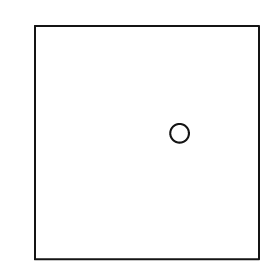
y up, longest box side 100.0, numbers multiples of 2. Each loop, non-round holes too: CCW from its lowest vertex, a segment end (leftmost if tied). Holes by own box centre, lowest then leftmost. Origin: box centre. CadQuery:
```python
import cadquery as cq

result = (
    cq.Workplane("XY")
    .moveTo(-48.0, -50.0)
    .lineTo(48.0, -50.0)
    .lineTo(48.0, 50.0)
    .lineTo(-48.0, 50.0)
    .close()
    .moveTo(14.0, 4.0)
    .circle(4.0)
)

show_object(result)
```